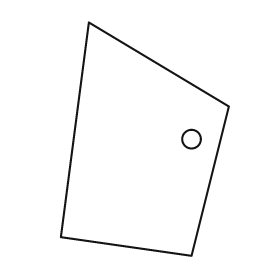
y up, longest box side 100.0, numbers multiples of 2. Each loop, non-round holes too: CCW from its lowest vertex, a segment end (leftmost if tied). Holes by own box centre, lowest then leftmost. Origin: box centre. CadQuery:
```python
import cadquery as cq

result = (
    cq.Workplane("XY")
    .moveTo(20.0, -50.0)
    .lineTo(36.0, 14.0)
    .lineTo(-24.0, 50.0)
    .lineTo(-36.0, -42.0)
    .close()
    .moveTo(20.0, 0.0)
    .circle(4.0)
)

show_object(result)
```